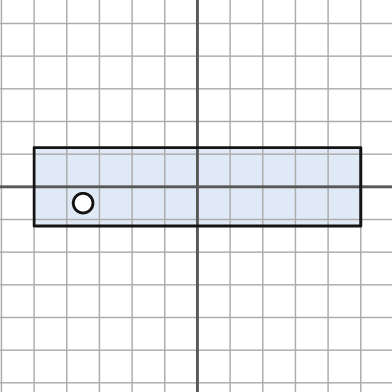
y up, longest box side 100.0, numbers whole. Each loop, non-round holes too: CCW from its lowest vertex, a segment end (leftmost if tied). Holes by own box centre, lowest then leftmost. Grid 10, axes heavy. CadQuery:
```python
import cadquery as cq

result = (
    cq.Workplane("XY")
    .moveTo(-50.0, -12.0)
    .lineTo(50.0, -12.0)
    .lineTo(50.0, 12.0)
    .lineTo(-50.0, 12.0)
    .close()
    .moveTo(-35.0, -5.0)
    .circle(3.0)
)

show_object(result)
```